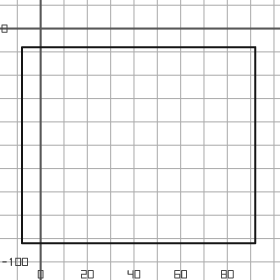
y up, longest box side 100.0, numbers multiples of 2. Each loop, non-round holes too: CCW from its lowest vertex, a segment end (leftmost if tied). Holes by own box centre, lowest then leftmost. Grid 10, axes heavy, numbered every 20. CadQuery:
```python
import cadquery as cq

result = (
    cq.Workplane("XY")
    .moveTo(-8.0, -92.0)
    .lineTo(92.0, -92.0)
    .lineTo(92.0, -8.0)
    .lineTo(-8.0, -8.0)
    .close()
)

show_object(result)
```